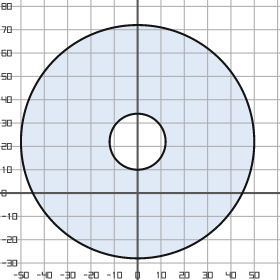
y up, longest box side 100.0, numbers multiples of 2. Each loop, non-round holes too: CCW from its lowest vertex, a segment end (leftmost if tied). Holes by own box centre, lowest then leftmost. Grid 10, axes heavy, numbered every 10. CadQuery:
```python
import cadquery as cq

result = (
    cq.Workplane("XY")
    .moveTo(0.0, 22.0)
    .circle(50.0)
    .moveTo(0.0, 22.0)
    .circle(12.0)
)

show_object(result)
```